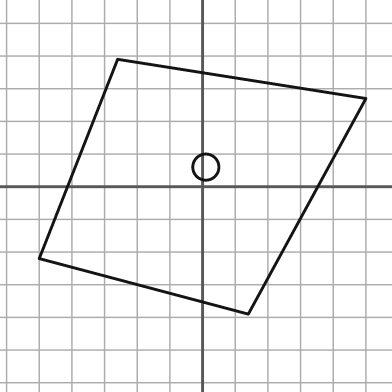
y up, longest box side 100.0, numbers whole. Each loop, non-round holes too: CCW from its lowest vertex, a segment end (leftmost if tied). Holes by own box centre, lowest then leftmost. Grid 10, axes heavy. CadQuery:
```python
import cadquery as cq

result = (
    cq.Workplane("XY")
    .moveTo(14.0, -39.0)
    .lineTo(50.0, 27.0)
    .lineTo(-26.0, 39.0)
    .lineTo(-50.0, -22.0)
    .close()
    .moveTo(1.0, 6.0)
    .circle(4.0)
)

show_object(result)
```